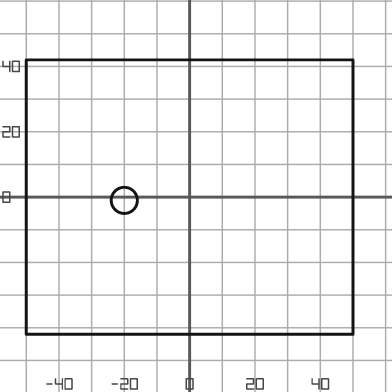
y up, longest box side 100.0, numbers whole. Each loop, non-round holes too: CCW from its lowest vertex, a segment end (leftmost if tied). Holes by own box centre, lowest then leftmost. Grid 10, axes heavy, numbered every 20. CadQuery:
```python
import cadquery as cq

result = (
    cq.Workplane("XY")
    .moveTo(-50.0, -42.0)
    .lineTo(50.0, -42.0)
    .lineTo(50.0, 42.0)
    .lineTo(-50.0, 42.0)
    .close()
    .moveTo(-20.0, -1.0)
    .circle(4.0)
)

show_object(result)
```